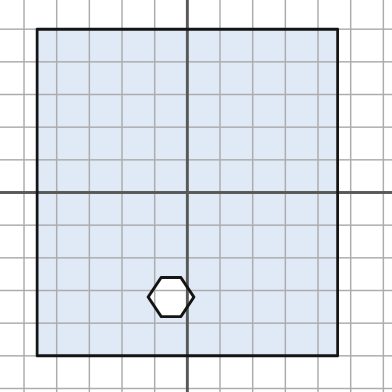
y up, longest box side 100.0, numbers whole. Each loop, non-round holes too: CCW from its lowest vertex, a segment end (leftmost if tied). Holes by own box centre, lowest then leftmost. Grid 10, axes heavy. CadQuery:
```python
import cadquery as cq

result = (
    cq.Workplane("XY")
    .moveTo(-46.0, -50.0)
    .lineTo(46.0, -50.0)
    .lineTo(46.0, 50.0)
    .lineTo(-46.0, 50.0)
    .close()
    .moveTo(-8.0, -38.0)
    .lineTo(-2.0, -38.0)
    .lineTo(2.0, -32.0)
    .lineTo(-2.0, -26.0)
    .lineTo(-8.0, -26.0)
    .lineTo(-12.0, -32.0)
    .close()
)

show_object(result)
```